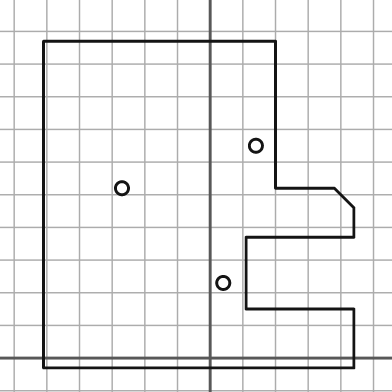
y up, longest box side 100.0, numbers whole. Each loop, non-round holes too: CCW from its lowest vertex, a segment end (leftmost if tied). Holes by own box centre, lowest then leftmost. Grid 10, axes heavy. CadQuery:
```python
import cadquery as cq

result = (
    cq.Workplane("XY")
    .moveTo(-51.0, -3.0)
    .lineTo(44.0, -3.0)
    .lineTo(44.0, 15.0)
    .lineTo(11.0, 15.0)
    .lineTo(11.0, 37.0)
    .lineTo(44.0, 37.0)
    .lineTo(44.0, 46.0)
    .lineTo(38.0, 52.0)
    .lineTo(20.0, 52.0)
    .lineTo(20.0, 97.0)
    .lineTo(-51.0, 97.0)
    .close()
    .moveTo(4.0, 23.0)
    .circle(2.0)
    .moveTo(-27.0, 52.0)
    .circle(2.0)
    .moveTo(14.0, 65.0)
    .circle(2.0)
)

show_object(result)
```